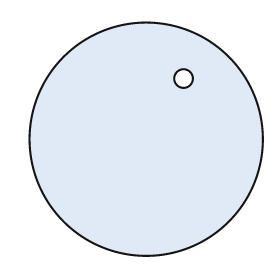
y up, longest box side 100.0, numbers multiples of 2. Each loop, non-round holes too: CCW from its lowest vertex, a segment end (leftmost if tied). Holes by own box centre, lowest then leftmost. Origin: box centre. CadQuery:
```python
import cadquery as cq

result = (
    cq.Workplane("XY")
    .moveTo(0.0, 0.0)
    .circle(50.0)
    .moveTo(16.0, 26.0)
    .circle(4.0)
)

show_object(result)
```